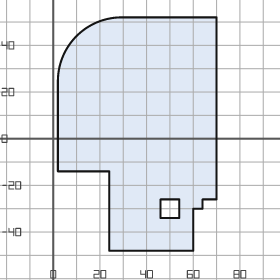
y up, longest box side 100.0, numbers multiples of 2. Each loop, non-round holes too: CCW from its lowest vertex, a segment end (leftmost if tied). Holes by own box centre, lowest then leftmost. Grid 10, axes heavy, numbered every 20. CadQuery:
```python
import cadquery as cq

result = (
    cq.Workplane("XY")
    .moveTo(24.0, -48.0)
    .lineTo(60.0, -48.0)
    .lineTo(60.0, -30.0)
    .lineTo(64.0, -30.0)
    .lineTo(64.0, -26.0)
    .lineTo(70.0, -26.0)
    .lineTo(70.0, 52.0)
    .lineTo(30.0, 52.0)
    .threePointArc((10.0, 44.0), (2.0, 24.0))
    .lineTo(2.0, -14.0)
    .lineTo(24.0, -14.0)
    .close()
    .moveTo(46.0, -34.0)
    .lineTo(54.0, -34.0)
    .lineTo(54.0, -26.0)
    .lineTo(46.0, -26.0)
    .close()
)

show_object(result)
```